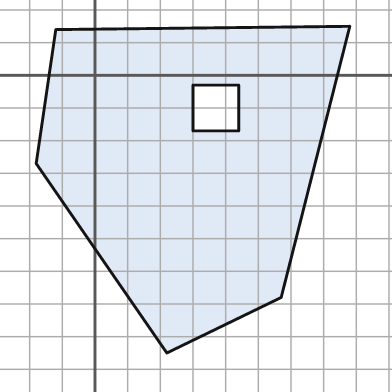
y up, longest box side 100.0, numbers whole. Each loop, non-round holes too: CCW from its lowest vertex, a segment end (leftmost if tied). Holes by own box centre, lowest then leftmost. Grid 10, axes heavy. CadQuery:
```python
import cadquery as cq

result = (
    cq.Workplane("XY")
    .moveTo(22.0, -85.0)
    .lineTo(57.0, -68.0)
    .lineTo(78.0, 15.0)
    .lineTo(-12.0, 14.0)
    .lineTo(-18.0, -27.0)
    .close()
    .moveTo(30.0, -17.0)
    .lineTo(44.0, -17.0)
    .lineTo(44.0, -3.0)
    .lineTo(30.0, -3.0)
    .close()
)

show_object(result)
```